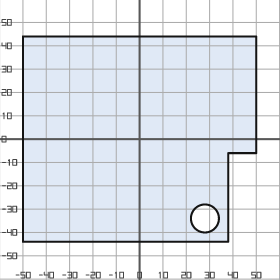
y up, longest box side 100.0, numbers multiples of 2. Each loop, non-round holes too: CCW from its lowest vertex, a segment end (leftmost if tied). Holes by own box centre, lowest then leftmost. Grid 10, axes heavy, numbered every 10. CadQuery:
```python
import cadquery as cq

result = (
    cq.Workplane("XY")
    .moveTo(-50.0, -44.0)
    .lineTo(38.0, -44.0)
    .lineTo(38.0, -6.0)
    .lineTo(50.0, -6.0)
    .lineTo(50.0, 44.0)
    .lineTo(-50.0, 44.0)
    .close()
    .moveTo(28.0, -34.0)
    .circle(6.0)
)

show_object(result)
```